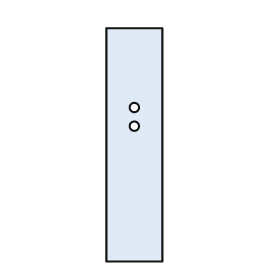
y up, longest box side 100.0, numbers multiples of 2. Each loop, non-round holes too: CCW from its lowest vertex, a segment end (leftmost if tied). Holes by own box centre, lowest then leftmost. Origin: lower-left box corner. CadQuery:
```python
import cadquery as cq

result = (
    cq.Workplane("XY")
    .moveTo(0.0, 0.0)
    .lineTo(24.0, 0.0)
    .lineTo(24.0, 100.0)
    .lineTo(0.0, 100.0)
    .close()
    .moveTo(12.0, 58.0)
    .circle(2.0)
    .moveTo(12.0, 66.0)
    .circle(2.0)
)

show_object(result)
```